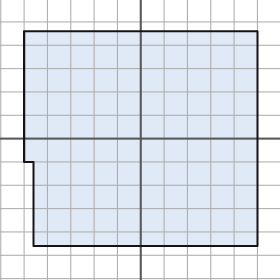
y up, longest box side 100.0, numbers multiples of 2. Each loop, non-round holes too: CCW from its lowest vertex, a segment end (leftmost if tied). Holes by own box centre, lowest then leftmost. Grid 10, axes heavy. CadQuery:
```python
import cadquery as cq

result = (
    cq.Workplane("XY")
    .moveTo(-46.0, -46.0)
    .lineTo(50.0, -46.0)
    .lineTo(50.0, 46.0)
    .lineTo(-50.0, 46.0)
    .lineTo(-50.0, -10.0)
    .lineTo(-46.0, -10.0)
    .close()
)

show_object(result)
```